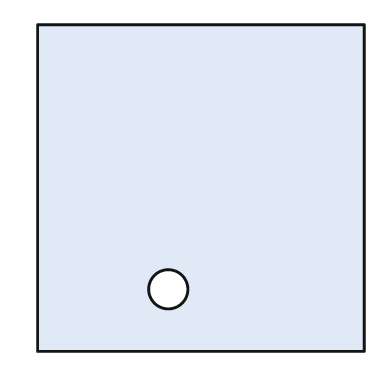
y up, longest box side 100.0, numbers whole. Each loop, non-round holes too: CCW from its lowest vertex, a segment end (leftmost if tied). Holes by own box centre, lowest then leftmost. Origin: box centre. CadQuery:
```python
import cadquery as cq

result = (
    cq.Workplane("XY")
    .moveTo(-50.0, -50.0)
    .lineTo(50.0, -50.0)
    .lineTo(50.0, 50.0)
    .lineTo(-50.0, 50.0)
    .close()
    .moveTo(-10.0, -31.0)
    .circle(6.0)
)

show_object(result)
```